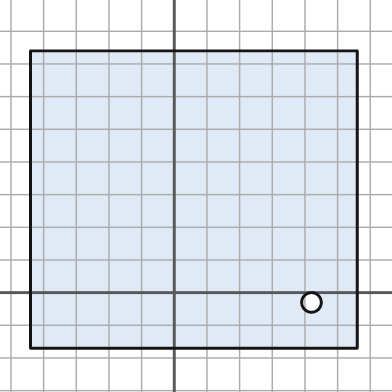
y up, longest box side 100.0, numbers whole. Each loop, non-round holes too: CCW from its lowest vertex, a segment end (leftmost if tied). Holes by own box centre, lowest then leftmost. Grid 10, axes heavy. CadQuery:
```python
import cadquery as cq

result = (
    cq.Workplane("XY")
    .moveTo(-44.0, -17.0)
    .lineTo(56.0, -17.0)
    .lineTo(56.0, 74.0)
    .lineTo(-44.0, 74.0)
    .close()
    .moveTo(42.0, -3.0)
    .circle(3.0)
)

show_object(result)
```